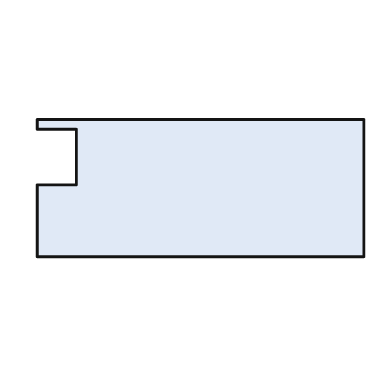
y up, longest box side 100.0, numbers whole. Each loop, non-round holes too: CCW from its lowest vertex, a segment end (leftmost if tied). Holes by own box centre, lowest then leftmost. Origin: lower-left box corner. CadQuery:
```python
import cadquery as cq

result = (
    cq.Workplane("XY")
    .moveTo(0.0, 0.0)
    .lineTo(100.0, 0.0)
    .lineTo(100.0, 42.0)
    .lineTo(0.0, 42.0)
    .lineTo(0.0, 39.0)
    .lineTo(12.0, 39.0)
    .lineTo(12.0, 22.0)
    .lineTo(0.0, 22.0)
    .close()
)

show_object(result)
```